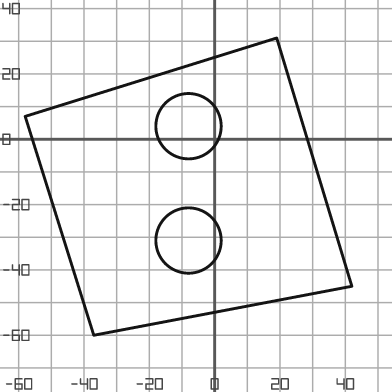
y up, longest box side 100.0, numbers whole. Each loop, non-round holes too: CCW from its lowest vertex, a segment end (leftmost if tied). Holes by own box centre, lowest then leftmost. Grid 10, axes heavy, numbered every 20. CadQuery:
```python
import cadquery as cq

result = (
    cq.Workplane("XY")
    .moveTo(-37.0, -60.0)
    .lineTo(42.0, -45.0)
    .lineTo(19.0, 31.0)
    .lineTo(-58.0, 7.0)
    .close()
    .moveTo(-8.0, -31.0)
    .circle(10.0)
    .moveTo(-8.0, 4.0)
    .circle(10.0)
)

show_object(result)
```